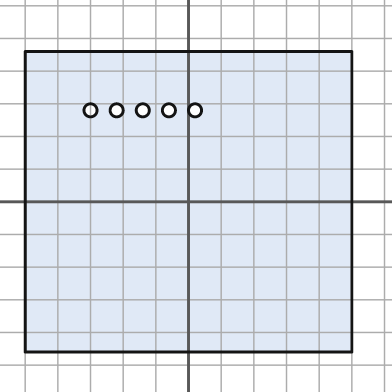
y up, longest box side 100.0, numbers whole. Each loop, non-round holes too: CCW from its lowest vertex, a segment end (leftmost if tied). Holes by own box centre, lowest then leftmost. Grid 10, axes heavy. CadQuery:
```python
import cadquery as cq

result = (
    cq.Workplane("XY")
    .moveTo(-50.0, -46.0)
    .lineTo(50.0, -46.0)
    .lineTo(50.0, 46.0)
    .lineTo(-50.0, 46.0)
    .close()
    .moveTo(-30.0, 28.0)
    .circle(2.0)
    .moveTo(-22.0, 28.0)
    .circle(2.0)
    .moveTo(-14.0, 28.0)
    .circle(2.0)
    .moveTo(-6.0, 28.0)
    .circle(2.0)
    .moveTo(2.0, 28.0)
    .circle(2.0)
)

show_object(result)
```